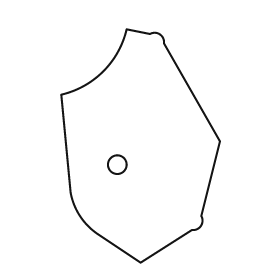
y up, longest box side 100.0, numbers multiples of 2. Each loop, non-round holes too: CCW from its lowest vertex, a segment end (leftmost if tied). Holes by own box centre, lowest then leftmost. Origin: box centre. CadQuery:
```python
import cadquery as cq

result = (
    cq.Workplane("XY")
    .moveTo(0.0, -50.0)
    .lineTo(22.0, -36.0)
    .threePointArc((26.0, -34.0), (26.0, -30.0))
    .lineTo(34.0, 2.0)
    .lineTo(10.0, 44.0)
    .threePointArc((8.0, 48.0), (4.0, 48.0))
    .lineTo(-6.0, 50.0)
    .threePointArc((-16.0, 32.0), (-34.0, 22.0))
    .lineTo(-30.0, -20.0)
    .threePointArc((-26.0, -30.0), (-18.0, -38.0))
    .close()
    .moveTo(-10.0, -8.0)
    .circle(4.0)
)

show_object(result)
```